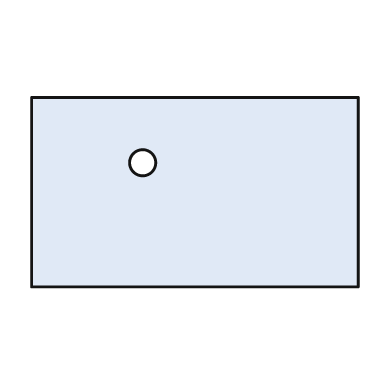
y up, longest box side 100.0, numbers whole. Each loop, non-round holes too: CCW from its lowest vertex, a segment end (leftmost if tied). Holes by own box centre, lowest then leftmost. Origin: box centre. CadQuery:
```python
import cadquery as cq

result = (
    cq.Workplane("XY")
    .moveTo(-50.0, -29.0)
    .lineTo(50.0, -29.0)
    .lineTo(50.0, 29.0)
    .lineTo(-50.0, 29.0)
    .close()
    .moveTo(-16.0, 9.0)
    .circle(4.0)
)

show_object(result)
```